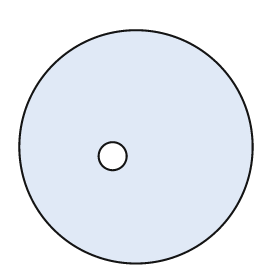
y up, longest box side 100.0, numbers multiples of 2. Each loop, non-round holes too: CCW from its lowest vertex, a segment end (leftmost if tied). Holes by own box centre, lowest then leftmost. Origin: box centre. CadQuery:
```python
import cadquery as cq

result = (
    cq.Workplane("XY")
    .moveTo(0.0, 0.0)
    .circle(50.0)
    .moveTo(-10.0, -4.0)
    .circle(6.0)
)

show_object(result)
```